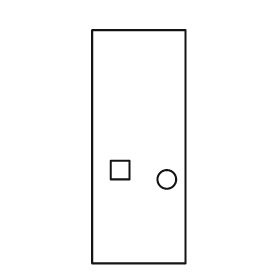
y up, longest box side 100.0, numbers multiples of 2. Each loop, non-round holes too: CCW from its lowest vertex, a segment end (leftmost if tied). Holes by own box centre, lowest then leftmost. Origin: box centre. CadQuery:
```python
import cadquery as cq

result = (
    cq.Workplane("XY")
    .moveTo(-20.0, -50.0)
    .lineTo(20.0, -50.0)
    .lineTo(20.0, 50.0)
    .lineTo(-20.0, 50.0)
    .close()
    .moveTo(12.0, -14.0)
    .circle(4.0)
    .moveTo(-12.0, -14.0)
    .lineTo(-4.0, -14.0)
    .lineTo(-4.0, -6.0)
    .lineTo(-12.0, -6.0)
    .close()
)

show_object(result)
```